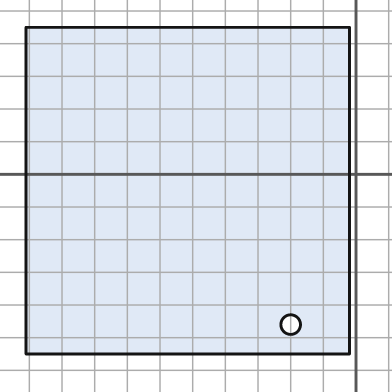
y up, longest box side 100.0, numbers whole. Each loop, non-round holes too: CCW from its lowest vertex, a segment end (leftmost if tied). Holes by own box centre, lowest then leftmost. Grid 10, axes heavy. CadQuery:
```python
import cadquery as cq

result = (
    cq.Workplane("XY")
    .moveTo(-101.0, -55.0)
    .lineTo(-2.0, -55.0)
    .lineTo(-2.0, 45.0)
    .lineTo(-101.0, 45.0)
    .close()
    .moveTo(-20.0, -46.0)
    .circle(3.0)
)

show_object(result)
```